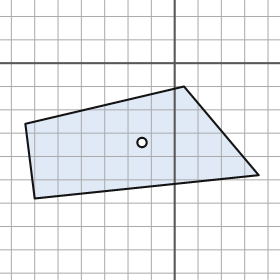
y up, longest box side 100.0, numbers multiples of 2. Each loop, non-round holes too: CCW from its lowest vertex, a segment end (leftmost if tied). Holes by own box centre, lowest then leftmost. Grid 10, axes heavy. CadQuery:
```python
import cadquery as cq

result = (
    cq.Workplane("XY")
    .moveTo(-60.0, -58.0)
    .lineTo(36.0, -48.0)
    .lineTo(4.0, -10.0)
    .lineTo(-64.0, -26.0)
    .close()
    .moveTo(-14.0, -34.0)
    .circle(2.0)
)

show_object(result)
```